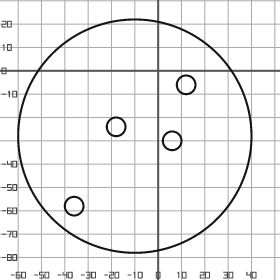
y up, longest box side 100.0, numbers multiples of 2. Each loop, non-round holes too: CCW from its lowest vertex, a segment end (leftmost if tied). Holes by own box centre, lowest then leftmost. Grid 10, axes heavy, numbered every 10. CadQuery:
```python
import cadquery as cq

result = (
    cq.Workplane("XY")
    .moveTo(-10.0, -28.0)
    .circle(50.0)
    .moveTo(-36.0, -58.0)
    .circle(4.0)
    .moveTo(6.0, -30.0)
    .circle(4.0)
    .moveTo(-18.0, -24.0)
    .circle(4.0)
    .moveTo(12.0, -6.0)
    .circle(4.0)
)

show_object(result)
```